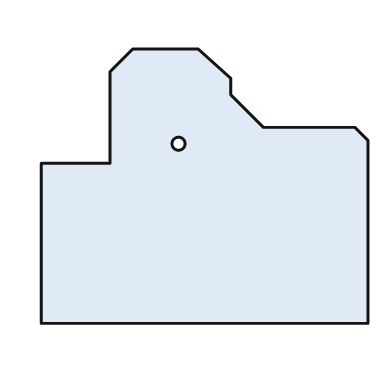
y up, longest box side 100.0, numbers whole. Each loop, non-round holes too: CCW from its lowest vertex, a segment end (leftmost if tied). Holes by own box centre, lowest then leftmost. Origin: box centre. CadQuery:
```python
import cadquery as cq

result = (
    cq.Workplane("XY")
    .moveTo(-50.0, -42.0)
    .lineTo(50.0, -42.0)
    .lineTo(50.0, 14.0)
    .lineTo(46.0, 18.0)
    .lineTo(18.0, 18.0)
    .lineTo(8.0, 28.0)
    .lineTo(8.0, 33.0)
    .lineTo(-2.0, 42.0)
    .lineTo(-22.0, 42.0)
    .lineTo(-29.0, 35.0)
    .lineTo(-29.0, 7.0)
    .lineTo(-50.0, 7.0)
    .close()
    .moveTo(-8.0, 13.0)
    .circle(2.0)
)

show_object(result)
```